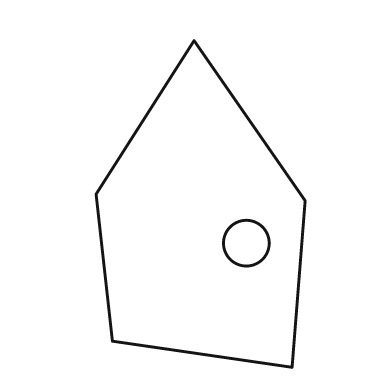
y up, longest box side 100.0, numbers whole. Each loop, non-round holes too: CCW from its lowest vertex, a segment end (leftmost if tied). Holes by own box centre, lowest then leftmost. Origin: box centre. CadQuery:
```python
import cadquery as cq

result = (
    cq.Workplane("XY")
    .moveTo(28.0, -50.0)
    .lineTo(32.0, 1.0)
    .lineTo(-2.0, 50.0)
    .lineTo(-32.0, 3.0)
    .lineTo(-27.0, -42.0)
    .close()
    .moveTo(14.0, -12.0)
    .circle(7.0)
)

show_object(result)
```